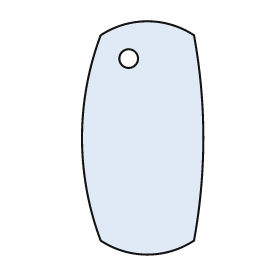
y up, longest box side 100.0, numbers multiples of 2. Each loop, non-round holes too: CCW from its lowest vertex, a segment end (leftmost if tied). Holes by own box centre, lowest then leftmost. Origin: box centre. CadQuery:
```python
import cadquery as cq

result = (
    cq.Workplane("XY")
    .moveTo(-18.0, -44.0)
    .threePointArc((2.0, -50.0), (22.0, -44.0))
    .threePointArc((26.0, 0.0), (22.0, 44.0))
    .threePointArc((2.0, 50.0), (-18.0, 44.0))
    .threePointArc((-26.0, 0.0), (-18.0, -44.0))
    .close()
    .moveTo(-6.0, 34.0)
    .circle(4.0)
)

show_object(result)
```